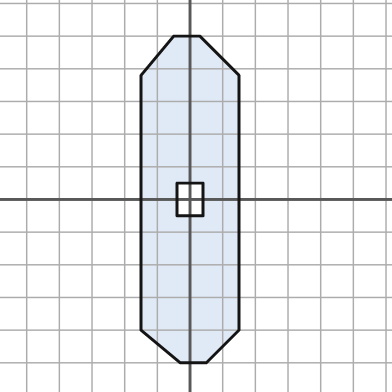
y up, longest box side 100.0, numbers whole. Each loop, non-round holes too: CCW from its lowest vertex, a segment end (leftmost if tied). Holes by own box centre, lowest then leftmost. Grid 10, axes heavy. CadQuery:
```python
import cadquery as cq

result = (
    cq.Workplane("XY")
    .moveTo(-3.0, -50.0)
    .lineTo(5.0, -50.0)
    .lineTo(15.0, -40.0)
    .lineTo(15.0, 38.0)
    .lineTo(3.0, 50.0)
    .lineTo(-5.0, 50.0)
    .lineTo(-15.0, 38.0)
    .lineTo(-15.0, -40.0)
    .close()
    .moveTo(-4.0, -5.0)
    .lineTo(4.0, -5.0)
    .lineTo(4.0, 5.0)
    .lineTo(-4.0, 5.0)
    .close()
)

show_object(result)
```